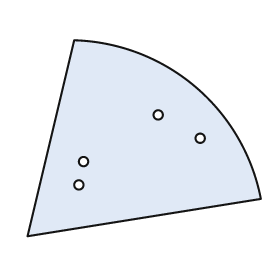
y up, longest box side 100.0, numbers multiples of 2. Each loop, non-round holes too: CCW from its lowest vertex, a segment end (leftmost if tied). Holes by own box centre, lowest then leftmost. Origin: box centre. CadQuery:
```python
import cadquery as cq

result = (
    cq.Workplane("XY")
    .moveTo(-50.0, -42.0)
    .lineTo(50.0, -26.0)
    .threePointArc((22.0, 22.0), (-30.0, 42.0))
    .close()
    .moveTo(-28.0, -20.0)
    .circle(2.0)
    .moveTo(-26.0, -10.0)
    .circle(2.0)
    .moveTo(24.0, 0.0)
    .circle(2.0)
    .moveTo(6.0, 10.0)
    .circle(2.0)
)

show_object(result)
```